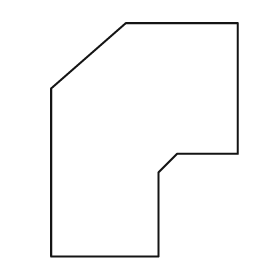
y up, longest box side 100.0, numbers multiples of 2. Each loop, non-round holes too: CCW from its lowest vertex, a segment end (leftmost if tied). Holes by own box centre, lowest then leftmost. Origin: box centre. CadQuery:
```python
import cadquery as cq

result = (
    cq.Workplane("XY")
    .moveTo(-40.0, -50.0)
    .lineTo(6.0, -50.0)
    .lineTo(6.0, -14.0)
    .lineTo(14.0, -6.0)
    .lineTo(40.0, -6.0)
    .lineTo(40.0, 50.0)
    .lineTo(-8.0, 50.0)
    .lineTo(-40.0, 22.0)
    .close()
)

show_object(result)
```